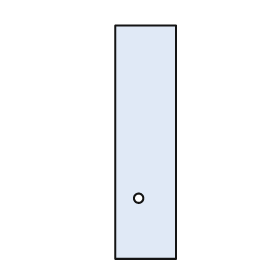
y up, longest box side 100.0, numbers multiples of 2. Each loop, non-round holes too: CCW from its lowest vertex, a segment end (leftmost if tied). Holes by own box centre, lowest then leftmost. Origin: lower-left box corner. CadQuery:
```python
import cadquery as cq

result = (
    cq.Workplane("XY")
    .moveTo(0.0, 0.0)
    .lineTo(26.0, 0.0)
    .lineTo(26.0, 100.0)
    .lineTo(0.0, 100.0)
    .close()
    .moveTo(10.0, 26.0)
    .circle(2.0)
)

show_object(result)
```